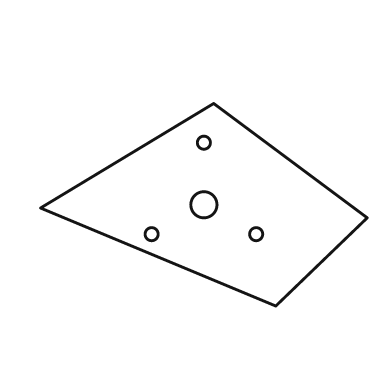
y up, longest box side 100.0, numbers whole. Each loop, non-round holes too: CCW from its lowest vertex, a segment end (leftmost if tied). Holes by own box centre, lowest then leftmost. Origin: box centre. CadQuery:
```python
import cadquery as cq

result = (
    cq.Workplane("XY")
    .moveTo(22.0, -31.0)
    .lineTo(50.0, -4.0)
    .lineTo(3.0, 31.0)
    .lineTo(-50.0, -1.0)
    .close()
    .moveTo(-16.0, -9.0)
    .circle(2.0)
    .moveTo(16.0, -9.0)
    .circle(2.0)
    .moveTo(0.0, 0.0)
    .circle(4.0)
    .moveTo(0.0, 19.0)
    .circle(2.0)
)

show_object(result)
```